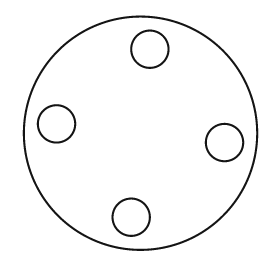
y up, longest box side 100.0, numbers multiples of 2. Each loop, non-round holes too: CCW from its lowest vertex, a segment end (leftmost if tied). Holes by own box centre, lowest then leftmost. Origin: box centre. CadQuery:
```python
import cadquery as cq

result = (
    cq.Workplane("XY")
    .moveTo(0.0, 0.0)
    .circle(50.0)
    .moveTo(-4.0, -36.0)
    .circle(8.0)
    .moveTo(36.0, -4.0)
    .circle(8.0)
    .moveTo(-36.0, 4.0)
    .circle(8.0)
    .moveTo(4.0, 36.0)
    .circle(8.0)
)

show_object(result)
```